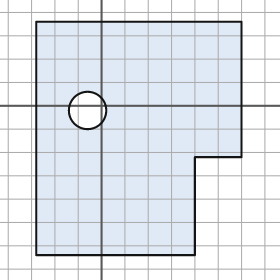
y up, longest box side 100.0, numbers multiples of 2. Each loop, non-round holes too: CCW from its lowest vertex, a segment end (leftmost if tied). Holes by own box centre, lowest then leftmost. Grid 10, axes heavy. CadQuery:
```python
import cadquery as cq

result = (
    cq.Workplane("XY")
    .moveTo(-28.0, -64.0)
    .lineTo(40.0, -64.0)
    .lineTo(40.0, -22.0)
    .lineTo(60.0, -22.0)
    .lineTo(60.0, 36.0)
    .lineTo(-28.0, 36.0)
    .close()
    .moveTo(-6.0, -2.0)
    .circle(8.0)
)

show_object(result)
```